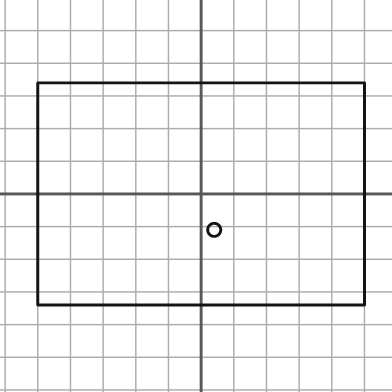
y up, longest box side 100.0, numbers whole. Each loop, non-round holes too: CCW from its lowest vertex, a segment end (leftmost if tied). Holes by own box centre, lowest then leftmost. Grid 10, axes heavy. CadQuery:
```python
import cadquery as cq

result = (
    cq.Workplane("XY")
    .moveTo(-50.0, -34.0)
    .lineTo(50.0, -34.0)
    .lineTo(50.0, 34.0)
    .lineTo(-50.0, 34.0)
    .close()
    .moveTo(4.0, -11.0)
    .circle(2.0)
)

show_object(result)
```